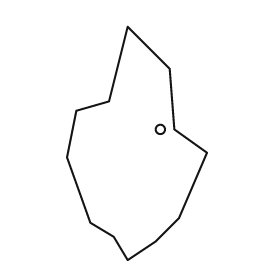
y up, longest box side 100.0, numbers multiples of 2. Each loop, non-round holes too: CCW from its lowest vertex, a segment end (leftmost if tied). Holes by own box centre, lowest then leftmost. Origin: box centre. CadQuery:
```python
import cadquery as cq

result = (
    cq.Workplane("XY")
    .moveTo(-4.0, -50.0)
    .lineTo(8.0, -42.0)
    .lineTo(18.0, -32.0)
    .lineTo(30.0, -4.0)
    .lineTo(16.0, 6.0)
    .lineTo(14.0, 32.0)
    .lineTo(-4.0, 50.0)
    .lineTo(-12.0, 18.0)
    .lineTo(-26.0, 14.0)
    .lineTo(-30.0, -6.0)
    .lineTo(-20.0, -34.0)
    .lineTo(-10.0, -40.0)
    .close()
    .moveTo(10.0, 6.0)
    .circle(2.0)
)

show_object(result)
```